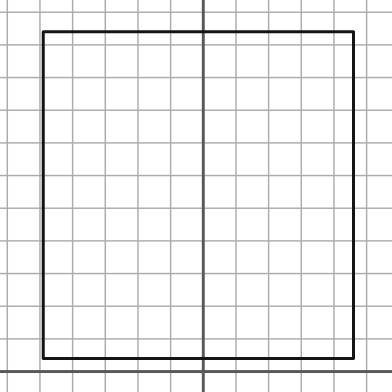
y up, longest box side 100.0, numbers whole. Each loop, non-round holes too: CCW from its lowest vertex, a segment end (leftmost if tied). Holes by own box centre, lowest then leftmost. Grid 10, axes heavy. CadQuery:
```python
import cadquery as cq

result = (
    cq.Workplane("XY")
    .moveTo(-49.0, 4.0)
    .lineTo(46.0, 4.0)
    .lineTo(46.0, 104.0)
    .lineTo(-49.0, 104.0)
    .close()
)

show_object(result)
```